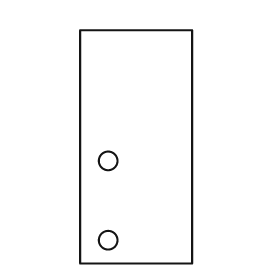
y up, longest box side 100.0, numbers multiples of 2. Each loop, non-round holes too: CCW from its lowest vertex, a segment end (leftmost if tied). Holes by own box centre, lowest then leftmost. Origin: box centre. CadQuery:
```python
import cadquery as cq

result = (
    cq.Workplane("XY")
    .moveTo(-24.0, -50.0)
    .lineTo(24.0, -50.0)
    .lineTo(24.0, 50.0)
    .lineTo(-24.0, 50.0)
    .close()
    .moveTo(-12.0, -40.0)
    .circle(4.0)
    .moveTo(-12.0, -6.0)
    .circle(4.0)
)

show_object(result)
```